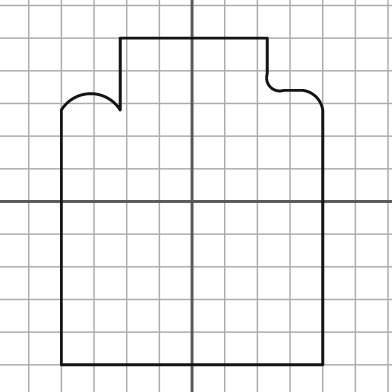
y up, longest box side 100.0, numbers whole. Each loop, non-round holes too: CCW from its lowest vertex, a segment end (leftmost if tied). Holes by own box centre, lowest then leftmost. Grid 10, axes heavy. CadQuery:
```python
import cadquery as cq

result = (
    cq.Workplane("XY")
    .moveTo(-40.0, -50.0)
    .lineTo(40.0, -50.0)
    .lineTo(40.0, 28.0)
    .threePointArc((38.0, 32.0), (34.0, 34.0))
    .lineTo(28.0, 34.0)
    .threePointArc((24.0, 35.0), (23.0, 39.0))
    .lineTo(23.0, 50.0)
    .lineTo(-22.0, 50.0)
    .lineTo(-22.0, 28.0)
    .threePointArc((-31.0, 33.0), (-40.0, 28.0))
    .close()
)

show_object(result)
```